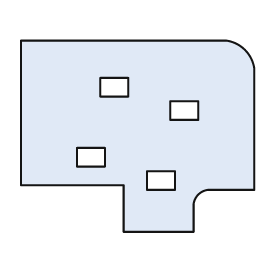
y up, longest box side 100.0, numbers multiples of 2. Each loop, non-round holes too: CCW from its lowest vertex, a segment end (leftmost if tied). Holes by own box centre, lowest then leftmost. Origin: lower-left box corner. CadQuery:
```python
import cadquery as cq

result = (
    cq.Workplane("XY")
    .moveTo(44.0, 0.0)
    .lineTo(74.0, 0.0)
    .lineTo(74.0, 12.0)
    .threePointArc((76.0, 16.0), (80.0, 18.0))
    .lineTo(100.0, 18.0)
    .lineTo(100.0, 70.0)
    .threePointArc((96.0, 78.0), (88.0, 82.0))
    .lineTo(0.0, 82.0)
    .lineTo(0.0, 20.0)
    .lineTo(44.0, 20.0)
    .close()
    .moveTo(54.0, 18.0)
    .lineTo(66.0, 18.0)
    .lineTo(66.0, 26.0)
    .lineTo(54.0, 26.0)
    .close()
    .moveTo(24.0, 28.0)
    .lineTo(36.0, 28.0)
    .lineTo(36.0, 36.0)
    .lineTo(24.0, 36.0)
    .close()
    .moveTo(64.0, 48.0)
    .lineTo(76.0, 48.0)
    .lineTo(76.0, 56.0)
    .lineTo(64.0, 56.0)
    .close()
    .moveTo(34.0, 58.0)
    .lineTo(46.0, 58.0)
    .lineTo(46.0, 66.0)
    .lineTo(34.0, 66.0)
    .close()
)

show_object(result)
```